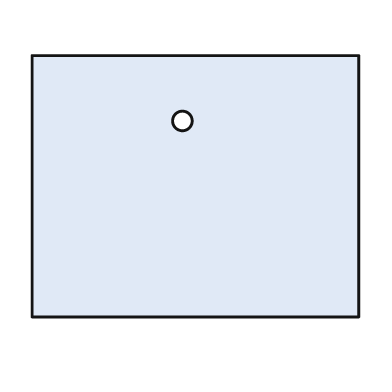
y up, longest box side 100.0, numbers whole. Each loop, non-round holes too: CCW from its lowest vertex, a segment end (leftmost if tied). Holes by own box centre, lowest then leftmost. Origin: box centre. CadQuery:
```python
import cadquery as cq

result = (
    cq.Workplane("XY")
    .moveTo(-50.0, -40.0)
    .lineTo(50.0, -40.0)
    .lineTo(50.0, 40.0)
    .lineTo(-50.0, 40.0)
    .close()
    .moveTo(-4.0, 20.0)
    .circle(3.0)
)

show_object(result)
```